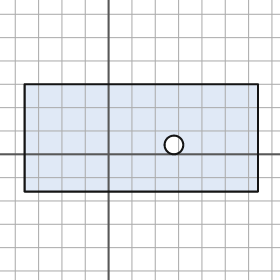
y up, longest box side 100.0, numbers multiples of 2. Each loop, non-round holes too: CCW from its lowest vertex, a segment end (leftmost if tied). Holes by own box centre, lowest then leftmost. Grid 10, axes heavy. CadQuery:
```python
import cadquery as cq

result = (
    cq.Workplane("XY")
    .moveTo(-36.0, -16.0)
    .lineTo(64.0, -16.0)
    .lineTo(64.0, 30.0)
    .lineTo(-36.0, 30.0)
    .close()
    .moveTo(28.0, 4.0)
    .circle(4.0)
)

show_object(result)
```